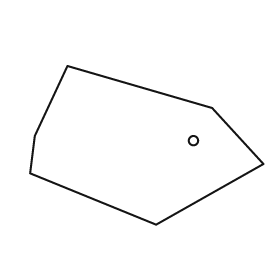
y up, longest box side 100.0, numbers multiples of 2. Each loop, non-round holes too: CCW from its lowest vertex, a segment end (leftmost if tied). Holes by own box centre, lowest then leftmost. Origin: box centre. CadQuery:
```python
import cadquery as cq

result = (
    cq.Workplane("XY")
    .moveTo(4.0, -34.0)
    .lineTo(50.0, -8.0)
    .lineTo(28.0, 16.0)
    .lineTo(-34.0, 34.0)
    .lineTo(-48.0, 4.0)
    .lineTo(-50.0, -12.0)
    .close()
    .moveTo(20.0, 2.0)
    .circle(2.0)
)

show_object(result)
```